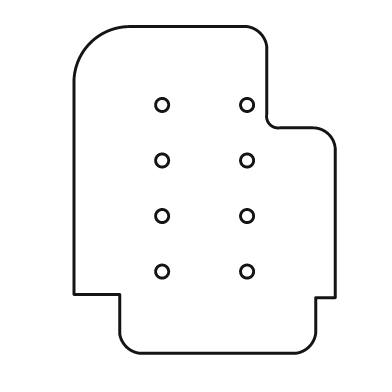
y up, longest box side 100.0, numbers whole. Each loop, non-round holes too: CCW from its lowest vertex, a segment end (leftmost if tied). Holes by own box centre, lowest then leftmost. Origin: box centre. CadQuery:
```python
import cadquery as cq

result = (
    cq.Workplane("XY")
    .moveTo(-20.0, -50.0)
    .lineTo(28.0, -50.0)
    .threePointArc((32.0, -48.0), (34.0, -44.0))
    .lineTo(34.0, -33.0)
    .lineTo(40.0, -33.0)
    .lineTo(40.0, 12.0)
    .threePointArc((38.0, 17.0), (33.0, 19.0))
    .lineTo(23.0, 19.0)
    .threePointArc((20.0, 20.0), (19.0, 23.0))
    .lineTo(19.0, 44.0)
    .threePointArc((17.0, 48.0), (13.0, 50.0))
    .lineTo(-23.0, 50.0)
    .threePointArc((-35.0, 45.0), (-40.0, 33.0))
    .lineTo(-40.0, -32.0)
    .lineTo(-26.0, -32.0)
    .lineTo(-26.0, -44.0)
    .threePointArc((-24.0, -48.0), (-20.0, -50.0))
    .close()
    .moveTo(-13.0, -25.0)
    .circle(2.0)
    .moveTo(13.0, -25.0)
    .circle(2.0)
    .moveTo(-13.0, -8.0)
    .circle(2.0)
    .moveTo(13.0, -8.0)
    .circle(2.0)
    .moveTo(-13.0, 9.0)
    .circle(2.0)
    .moveTo(13.0, 9.0)
    .circle(2.0)
    .moveTo(-13.0, 26.0)
    .circle(2.0)
    .moveTo(13.0, 26.0)
    .circle(2.0)
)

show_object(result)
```